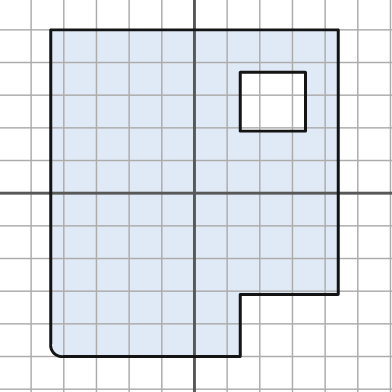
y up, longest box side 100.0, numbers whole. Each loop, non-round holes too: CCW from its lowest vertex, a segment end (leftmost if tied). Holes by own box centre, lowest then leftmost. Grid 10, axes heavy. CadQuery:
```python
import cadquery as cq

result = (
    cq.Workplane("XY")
    .moveTo(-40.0, -50.0)
    .lineTo(14.0, -50.0)
    .lineTo(14.0, -31.0)
    .lineTo(44.0, -31.0)
    .lineTo(44.0, 50.0)
    .lineTo(-44.0, 50.0)
    .lineTo(-44.0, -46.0)
    .threePointArc((-43.0, -49.0), (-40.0, -50.0))
    .close()
    .moveTo(14.0, 19.0)
    .lineTo(34.0, 19.0)
    .lineTo(34.0, 37.0)
    .lineTo(14.0, 37.0)
    .close()
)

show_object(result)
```